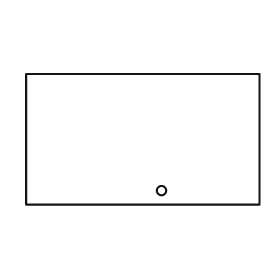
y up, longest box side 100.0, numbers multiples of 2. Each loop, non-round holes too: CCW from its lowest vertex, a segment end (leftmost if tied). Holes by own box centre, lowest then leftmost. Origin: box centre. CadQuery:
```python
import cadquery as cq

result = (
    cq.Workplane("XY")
    .moveTo(-50.0, -28.0)
    .lineTo(50.0, -28.0)
    .lineTo(50.0, 28.0)
    .lineTo(-50.0, 28.0)
    .close()
    .moveTo(8.0, -22.0)
    .circle(2.0)
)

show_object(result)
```